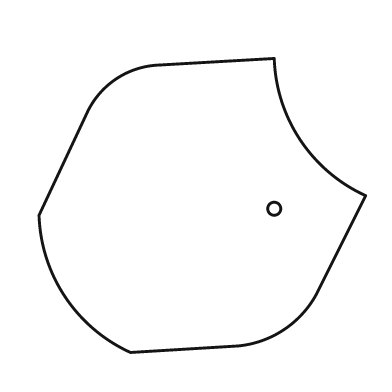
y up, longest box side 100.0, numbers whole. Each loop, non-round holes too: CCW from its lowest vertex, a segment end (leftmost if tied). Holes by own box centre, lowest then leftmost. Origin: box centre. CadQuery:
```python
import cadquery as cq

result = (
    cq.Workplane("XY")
    .moveTo(-22.0, -45.0)
    .lineTo(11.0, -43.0)
    .threePointArc((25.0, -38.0), (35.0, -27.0))
    .lineTo(50.0, 3.0)
    .threePointArc((30.0, 20.0), (22.0, 45.0))
    .lineTo(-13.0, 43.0)
    .threePointArc((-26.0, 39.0), (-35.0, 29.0))
    .lineTo(-50.0, -3.0)
    .threePointArc((-42.0, -28.0), (-22.0, -45.0))
    .close()
    .moveTo(22.0, -1.0)
    .circle(2.0)
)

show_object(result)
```